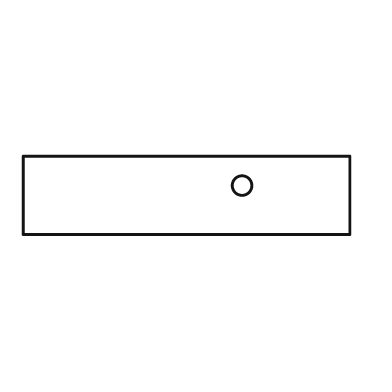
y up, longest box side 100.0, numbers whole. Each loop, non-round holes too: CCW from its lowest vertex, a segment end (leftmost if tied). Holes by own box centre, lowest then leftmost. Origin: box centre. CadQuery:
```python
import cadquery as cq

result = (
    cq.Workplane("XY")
    .moveTo(-50.0, -12.0)
    .lineTo(50.0, -12.0)
    .lineTo(50.0, 12.0)
    .lineTo(-50.0, 12.0)
    .close()
    .moveTo(17.0, 3.0)
    .circle(3.0)
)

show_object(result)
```